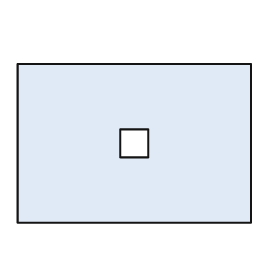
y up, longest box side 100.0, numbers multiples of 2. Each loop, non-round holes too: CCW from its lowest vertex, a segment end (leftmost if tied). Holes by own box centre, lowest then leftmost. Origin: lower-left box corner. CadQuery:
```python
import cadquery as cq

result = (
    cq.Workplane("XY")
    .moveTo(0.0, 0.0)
    .lineTo(100.0, 0.0)
    .lineTo(100.0, 68.0)
    .lineTo(0.0, 68.0)
    .close()
    .moveTo(44.0, 28.0)
    .lineTo(56.0, 28.0)
    .lineTo(56.0, 40.0)
    .lineTo(44.0, 40.0)
    .close()
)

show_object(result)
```